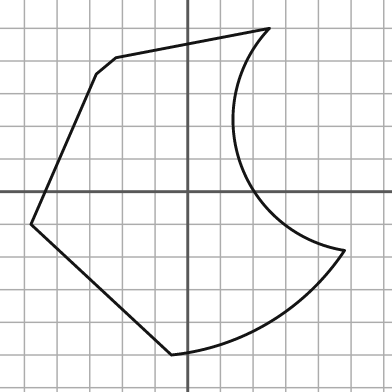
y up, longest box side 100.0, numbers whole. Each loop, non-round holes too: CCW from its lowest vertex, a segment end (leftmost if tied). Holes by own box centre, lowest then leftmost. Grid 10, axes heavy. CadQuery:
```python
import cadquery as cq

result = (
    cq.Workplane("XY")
    .moveTo(-5.0, -50.0)
    .threePointArc((25.0, -40.0), (48.0, -18.0))
    .threePointArc((16.0, 9.0), (25.0, 50.0))
    .lineTo(-22.0, 41.0)
    .lineTo(-28.0, 36.0)
    .lineTo(-48.0, -10.0)
    .close()
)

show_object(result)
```